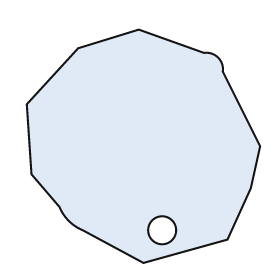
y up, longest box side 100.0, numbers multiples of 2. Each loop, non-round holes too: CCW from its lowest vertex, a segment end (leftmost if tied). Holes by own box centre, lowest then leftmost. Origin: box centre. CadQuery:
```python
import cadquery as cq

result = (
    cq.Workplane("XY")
    .moveTo(0.0, -50.0)
    .lineTo(36.0, -40.0)
    .lineTo(46.0, -18.0)
    .lineTo(50.0, 0.0)
    .lineTo(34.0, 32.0)
    .threePointArc((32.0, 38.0), (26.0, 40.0))
    .lineTo(-2.0, 50.0)
    .lineTo(-28.0, 42.0)
    .lineTo(-50.0, 18.0)
    .lineTo(-48.0, -12.0)
    .lineTo(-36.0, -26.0)
    .threePointArc((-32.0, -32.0), (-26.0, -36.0))
    .close()
    .moveTo(8.0, -36.0)
    .circle(6.0)
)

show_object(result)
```